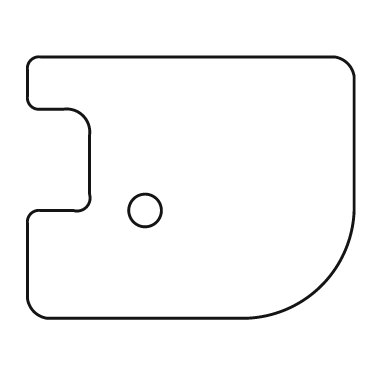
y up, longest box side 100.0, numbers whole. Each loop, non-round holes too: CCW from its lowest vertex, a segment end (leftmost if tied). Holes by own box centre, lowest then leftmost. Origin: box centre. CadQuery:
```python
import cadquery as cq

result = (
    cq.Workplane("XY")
    .moveTo(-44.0, -40.0)
    .lineTo(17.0, -40.0)
    .threePointArc((40.0, -30.0), (50.0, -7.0))
    .lineTo(50.0, 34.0)
    .threePointArc((48.0, 38.0), (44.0, 40.0))
    .lineTo(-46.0, 40.0)
    .threePointArc((-49.0, 39.0), (-50.0, 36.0))
    .lineTo(-50.0, 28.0)
    .threePointArc((-49.0, 25.0), (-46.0, 24.0))
    .lineTo(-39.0, 24.0)
    .threePointArc((-33.0, 22.0), (-31.0, 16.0))
    .lineTo(-31.0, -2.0)
    .threePointArc((-32.0, -6.0), (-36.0, -7.0))
    .lineTo(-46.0, -7.0)
    .threePointArc((-49.0, -8.0), (-50.0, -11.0))
    .lineTo(-50.0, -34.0)
    .threePointArc((-48.0, -38.0), (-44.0, -40.0))
    .close()
    .moveTo(-14.0, -7.0)
    .circle(5.0)
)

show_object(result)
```